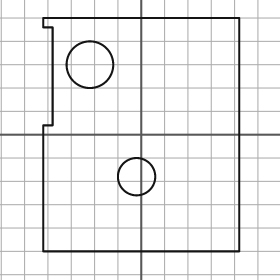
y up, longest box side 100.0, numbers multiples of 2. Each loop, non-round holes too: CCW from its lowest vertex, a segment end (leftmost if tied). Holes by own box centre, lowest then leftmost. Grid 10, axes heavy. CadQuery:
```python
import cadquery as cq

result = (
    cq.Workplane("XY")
    .moveTo(-42.0, -50.0)
    .lineTo(42.0, -50.0)
    .lineTo(42.0, 50.0)
    .lineTo(-42.0, 50.0)
    .lineTo(-42.0, 46.0)
    .lineTo(-38.0, 46.0)
    .lineTo(-38.0, 4.0)
    .lineTo(-42.0, 4.0)
    .close()
    .moveTo(-2.0, -18.0)
    .circle(8.0)
    .moveTo(-22.0, 30.0)
    .circle(10.0)
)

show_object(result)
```